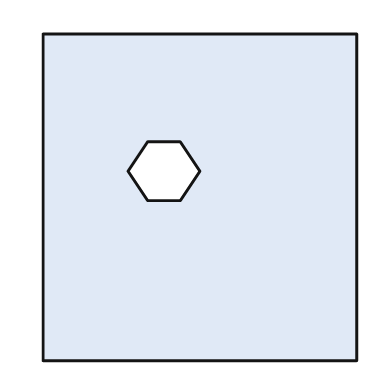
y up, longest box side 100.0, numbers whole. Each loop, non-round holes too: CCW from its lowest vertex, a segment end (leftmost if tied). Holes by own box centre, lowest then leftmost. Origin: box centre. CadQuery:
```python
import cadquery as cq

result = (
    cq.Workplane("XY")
    .moveTo(-48.0, -50.0)
    .lineTo(48.0, -50.0)
    .lineTo(48.0, 50.0)
    .lineTo(-48.0, 50.0)
    .close()
    .moveTo(-16.0, -1.0)
    .lineTo(-6.0, -1.0)
    .lineTo(0.0, 8.0)
    .lineTo(-6.0, 17.0)
    .lineTo(-16.0, 17.0)
    .lineTo(-22.0, 8.0)
    .close()
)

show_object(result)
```